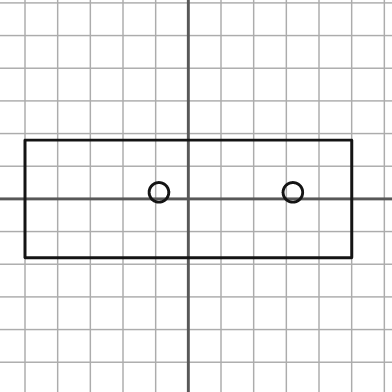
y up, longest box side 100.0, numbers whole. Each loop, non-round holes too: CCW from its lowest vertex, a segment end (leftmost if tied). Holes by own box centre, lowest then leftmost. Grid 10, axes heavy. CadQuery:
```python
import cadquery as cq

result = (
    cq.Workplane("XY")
    .moveTo(-50.0, -18.0)
    .lineTo(50.0, -18.0)
    .lineTo(50.0, 18.0)
    .lineTo(-50.0, 18.0)
    .close()
    .moveTo(-9.0, 2.0)
    .circle(3.0)
    .moveTo(32.0, 2.0)
    .circle(3.0)
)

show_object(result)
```